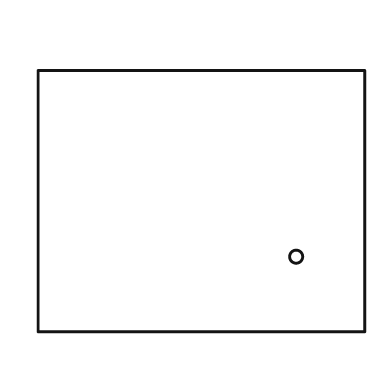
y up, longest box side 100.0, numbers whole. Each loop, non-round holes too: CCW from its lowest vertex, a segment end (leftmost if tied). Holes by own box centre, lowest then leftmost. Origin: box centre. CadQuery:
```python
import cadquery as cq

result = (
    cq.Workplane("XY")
    .moveTo(-50.0, -40.0)
    .lineTo(50.0, -40.0)
    .lineTo(50.0, 40.0)
    .lineTo(-50.0, 40.0)
    .close()
    .moveTo(29.0, -17.0)
    .circle(2.0)
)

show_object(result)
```